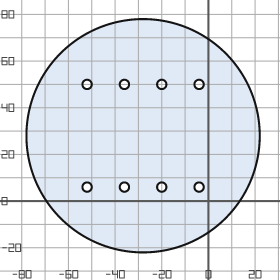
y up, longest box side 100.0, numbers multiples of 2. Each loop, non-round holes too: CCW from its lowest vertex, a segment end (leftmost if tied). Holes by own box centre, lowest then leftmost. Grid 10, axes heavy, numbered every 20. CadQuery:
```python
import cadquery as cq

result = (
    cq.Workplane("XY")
    .moveTo(-28.0, 28.0)
    .circle(50.0)
    .moveTo(-52.0, 6.0)
    .circle(2.0)
    .moveTo(-36.0, 6.0)
    .circle(2.0)
    .moveTo(-20.0, 6.0)
    .circle(2.0)
    .moveTo(-4.0, 6.0)
    .circle(2.0)
    .moveTo(-52.0, 50.0)
    .circle(2.0)
    .moveTo(-36.0, 50.0)
    .circle(2.0)
    .moveTo(-20.0, 50.0)
    .circle(2.0)
    .moveTo(-4.0, 50.0)
    .circle(2.0)
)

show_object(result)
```